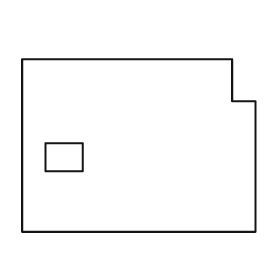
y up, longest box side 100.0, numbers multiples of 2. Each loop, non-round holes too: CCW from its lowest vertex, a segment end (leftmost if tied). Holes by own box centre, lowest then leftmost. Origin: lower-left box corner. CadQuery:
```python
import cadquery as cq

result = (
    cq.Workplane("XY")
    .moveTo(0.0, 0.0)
    .lineTo(100.0, 0.0)
    .lineTo(100.0, 56.0)
    .lineTo(90.0, 56.0)
    .lineTo(90.0, 74.0)
    .lineTo(0.0, 74.0)
    .close()
    .moveTo(10.0, 26.0)
    .lineTo(26.0, 26.0)
    .lineTo(26.0, 38.0)
    .lineTo(10.0, 38.0)
    .close()
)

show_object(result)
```